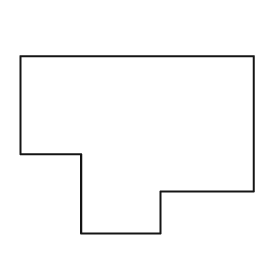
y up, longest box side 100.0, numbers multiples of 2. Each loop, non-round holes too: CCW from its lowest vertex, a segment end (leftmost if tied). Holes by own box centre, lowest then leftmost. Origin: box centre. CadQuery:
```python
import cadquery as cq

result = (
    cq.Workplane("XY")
    .moveTo(-24.0, -38.0)
    .lineTo(10.0, -38.0)
    .lineTo(10.0, -20.0)
    .lineTo(50.0, -20.0)
    .lineTo(50.0, 38.0)
    .lineTo(-50.0, 38.0)
    .lineTo(-50.0, -4.0)
    .lineTo(-24.0, -4.0)
    .close()
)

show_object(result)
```